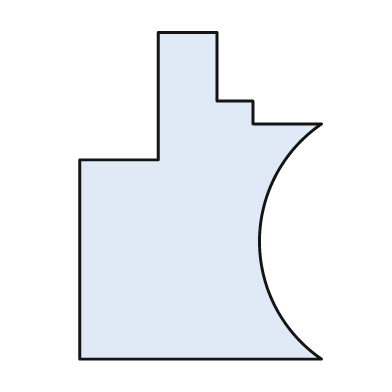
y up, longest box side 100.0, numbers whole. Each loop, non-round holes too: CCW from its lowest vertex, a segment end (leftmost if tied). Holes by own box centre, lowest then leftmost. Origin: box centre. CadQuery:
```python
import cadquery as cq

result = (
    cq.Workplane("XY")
    .moveTo(-37.0, -50.0)
    .lineTo(37.0, -50.0)
    .threePointArc((18.0, -14.0), (37.0, 22.0))
    .lineTo(16.0, 22.0)
    .lineTo(16.0, 29.0)
    .lineTo(5.0, 29.0)
    .lineTo(5.0, 50.0)
    .lineTo(-13.0, 50.0)
    .lineTo(-13.0, 11.0)
    .lineTo(-37.0, 11.0)
    .close()
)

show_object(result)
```